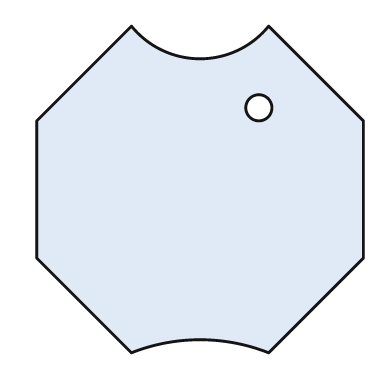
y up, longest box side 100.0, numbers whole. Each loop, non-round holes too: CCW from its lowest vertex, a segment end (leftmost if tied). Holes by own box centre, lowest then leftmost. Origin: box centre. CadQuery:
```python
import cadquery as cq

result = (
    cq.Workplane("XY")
    .moveTo(-21.0, -50.0)
    .threePointArc((0.0, -46.0), (21.0, -50.0))
    .lineTo(50.0, -21.0)
    .lineTo(50.0, 21.0)
    .lineTo(21.0, 50.0)
    .threePointArc((0.0, 40.0), (-21.0, 50.0))
    .lineTo(-50.0, 21.0)
    .lineTo(-50.0, -21.0)
    .close()
    .moveTo(18.0, 25.0)
    .circle(4.0)
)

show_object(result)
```